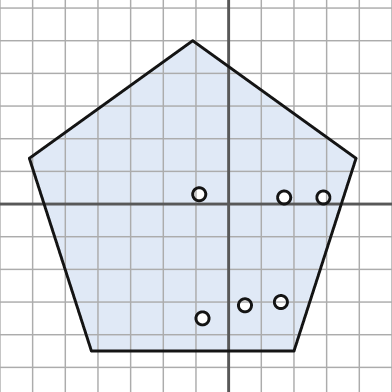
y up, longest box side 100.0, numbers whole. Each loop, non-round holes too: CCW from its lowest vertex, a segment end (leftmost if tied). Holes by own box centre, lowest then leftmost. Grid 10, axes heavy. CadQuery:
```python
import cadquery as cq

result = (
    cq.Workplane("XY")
    .moveTo(-42.0, -45.0)
    .lineTo(20.0, -45.0)
    .lineTo(39.0, 14.0)
    .lineTo(-11.0, 50.0)
    .lineTo(-61.0, 14.0)
    .close()
    .moveTo(-8.0, -35.0)
    .circle(2.0)
    .moveTo(5.0, -31.0)
    .circle(2.0)
    .moveTo(16.0, -30.0)
    .circle(2.0)
    .moveTo(17.0, 2.0)
    .circle(2.0)
    .moveTo(29.0, 2.0)
    .circle(2.0)
    .moveTo(-9.0, 3.0)
    .circle(2.0)
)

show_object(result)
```